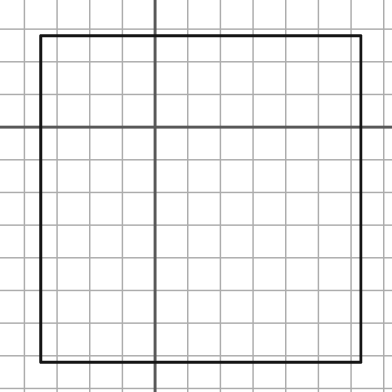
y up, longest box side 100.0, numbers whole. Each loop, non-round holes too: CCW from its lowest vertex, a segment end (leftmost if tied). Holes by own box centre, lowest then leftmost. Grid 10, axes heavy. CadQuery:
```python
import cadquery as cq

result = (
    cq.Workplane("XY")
    .moveTo(-35.0, -72.0)
    .lineTo(63.0, -72.0)
    .lineTo(63.0, 28.0)
    .lineTo(-35.0, 28.0)
    .close()
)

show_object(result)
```